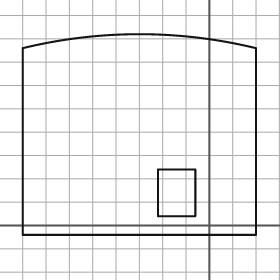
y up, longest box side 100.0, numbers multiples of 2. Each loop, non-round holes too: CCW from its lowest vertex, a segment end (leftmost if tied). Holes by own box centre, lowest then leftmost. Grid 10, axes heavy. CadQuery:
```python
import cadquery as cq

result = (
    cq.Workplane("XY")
    .moveTo(-80.0, -4.0)
    .lineTo(20.0, -4.0)
    .lineTo(20.0, 76.0)
    .threePointArc((-30.0, 82.0), (-80.0, 76.0))
    .close()
    .moveTo(-22.0, 4.0)
    .lineTo(-6.0, 4.0)
    .lineTo(-6.0, 24.0)
    .lineTo(-22.0, 24.0)
    .close()
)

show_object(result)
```